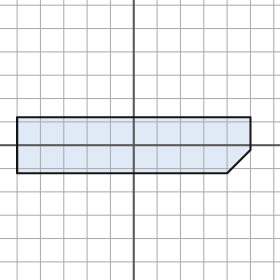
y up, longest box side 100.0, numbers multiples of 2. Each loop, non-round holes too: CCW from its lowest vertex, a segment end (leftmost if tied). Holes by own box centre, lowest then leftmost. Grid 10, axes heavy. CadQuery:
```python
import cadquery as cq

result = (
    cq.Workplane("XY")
    .moveTo(-50.0, -12.0)
    .lineTo(40.0, -12.0)
    .lineTo(50.0, -2.0)
    .lineTo(50.0, 12.0)
    .lineTo(-50.0, 12.0)
    .close()
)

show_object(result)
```